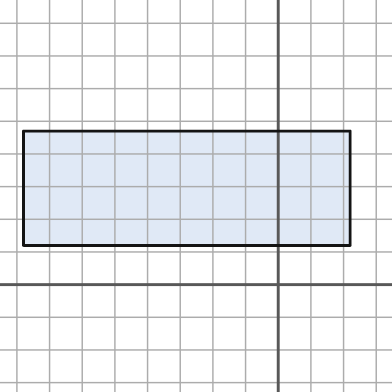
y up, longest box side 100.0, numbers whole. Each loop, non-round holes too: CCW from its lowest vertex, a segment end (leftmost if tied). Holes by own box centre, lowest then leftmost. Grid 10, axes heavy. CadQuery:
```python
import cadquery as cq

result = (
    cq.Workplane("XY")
    .moveTo(-78.0, 12.0)
    .lineTo(22.0, 12.0)
    .lineTo(22.0, 47.0)
    .lineTo(-78.0, 47.0)
    .close()
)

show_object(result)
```